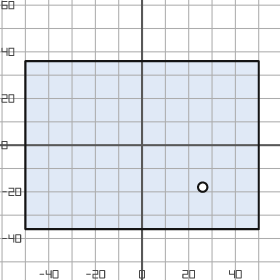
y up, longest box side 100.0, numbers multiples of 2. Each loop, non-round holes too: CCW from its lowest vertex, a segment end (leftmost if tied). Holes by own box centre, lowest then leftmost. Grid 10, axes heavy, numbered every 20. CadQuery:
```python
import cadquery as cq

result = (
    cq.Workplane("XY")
    .moveTo(-50.0, -36.0)
    .lineTo(50.0, -36.0)
    .lineTo(50.0, 36.0)
    .lineTo(-50.0, 36.0)
    .close()
    .moveTo(26.0, -18.0)
    .circle(2.0)
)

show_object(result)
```